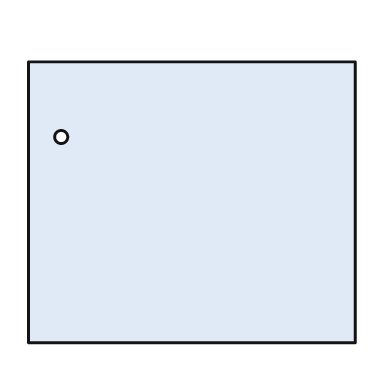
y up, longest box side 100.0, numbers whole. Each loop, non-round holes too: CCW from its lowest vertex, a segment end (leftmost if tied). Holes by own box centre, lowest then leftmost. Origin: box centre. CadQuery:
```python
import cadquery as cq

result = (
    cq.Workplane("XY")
    .moveTo(-50.0, -43.0)
    .lineTo(50.0, -43.0)
    .lineTo(50.0, 43.0)
    .lineTo(-50.0, 43.0)
    .close()
    .moveTo(-40.0, 20.0)
    .circle(2.0)
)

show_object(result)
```